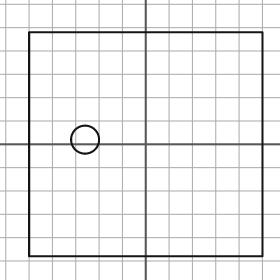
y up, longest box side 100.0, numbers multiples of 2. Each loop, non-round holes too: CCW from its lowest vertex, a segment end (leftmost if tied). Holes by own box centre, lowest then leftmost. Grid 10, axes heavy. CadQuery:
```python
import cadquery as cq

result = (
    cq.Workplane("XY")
    .moveTo(-50.0, -48.0)
    .lineTo(50.0, -48.0)
    .lineTo(50.0, 48.0)
    .lineTo(-50.0, 48.0)
    .close()
    .moveTo(-26.0, 2.0)
    .circle(6.0)
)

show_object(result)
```